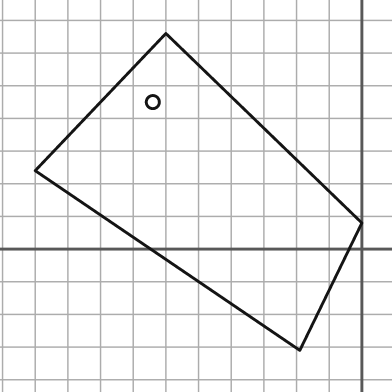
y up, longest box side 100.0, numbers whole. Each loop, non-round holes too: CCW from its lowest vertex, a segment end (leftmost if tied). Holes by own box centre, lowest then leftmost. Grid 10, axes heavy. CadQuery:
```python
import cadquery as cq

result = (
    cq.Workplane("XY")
    .moveTo(-19.0, -31.0)
    .lineTo(0.0, 8.0)
    .lineTo(-60.0, 66.0)
    .lineTo(-100.0, 24.0)
    .close()
    .moveTo(-64.0, 45.0)
    .circle(2.0)
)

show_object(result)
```